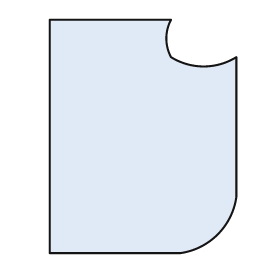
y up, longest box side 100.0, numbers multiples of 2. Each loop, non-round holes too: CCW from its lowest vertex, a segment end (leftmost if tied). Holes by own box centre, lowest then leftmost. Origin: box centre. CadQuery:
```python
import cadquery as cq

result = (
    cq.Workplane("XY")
    .moveTo(-40.0, -50.0)
    .lineTo(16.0, -50.0)
    .threePointArc((32.0, -42.0), (40.0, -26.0))
    .lineTo(40.0, 34.0)
    .threePointArc((26.0, 30.0), (12.0, 34.0))
    .threePointArc((10.0, 42.0), (12.0, 50.0))
    .lineTo(-40.0, 50.0)
    .close()
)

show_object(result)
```